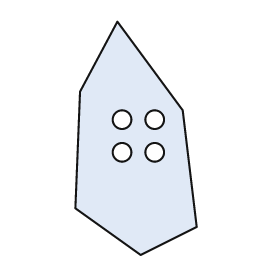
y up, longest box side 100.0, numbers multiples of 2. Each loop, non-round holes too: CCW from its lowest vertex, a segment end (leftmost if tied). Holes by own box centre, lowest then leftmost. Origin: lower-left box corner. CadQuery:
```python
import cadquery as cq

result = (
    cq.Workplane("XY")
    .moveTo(28.0, 0.0)
    .lineTo(52.0, 12.0)
    .lineTo(46.0, 62.0)
    .lineTo(18.0, 100.0)
    .lineTo(2.0, 70.0)
    .lineTo(0.0, 20.0)
    .close()
    .moveTo(20.0, 44.0)
    .circle(4.0)
    .moveTo(34.0, 44.0)
    .circle(4.0)
    .moveTo(20.0, 58.0)
    .circle(4.0)
    .moveTo(34.0, 58.0)
    .circle(4.0)
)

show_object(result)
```